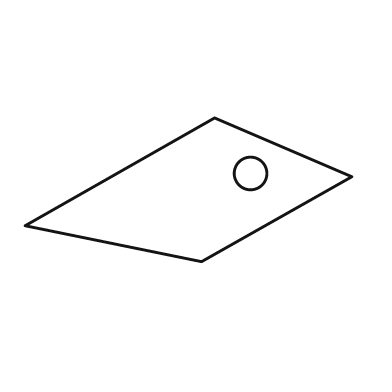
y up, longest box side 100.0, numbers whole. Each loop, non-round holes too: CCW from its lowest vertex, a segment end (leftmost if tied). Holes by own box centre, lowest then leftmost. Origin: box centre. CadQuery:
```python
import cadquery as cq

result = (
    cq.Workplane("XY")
    .moveTo(4.0, -22.0)
    .lineTo(50.0, 4.0)
    .lineTo(8.0, 22.0)
    .lineTo(-50.0, -11.0)
    .close()
    .moveTo(19.0, 5.0)
    .circle(5.0)
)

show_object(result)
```